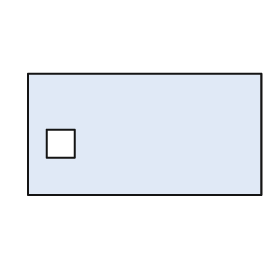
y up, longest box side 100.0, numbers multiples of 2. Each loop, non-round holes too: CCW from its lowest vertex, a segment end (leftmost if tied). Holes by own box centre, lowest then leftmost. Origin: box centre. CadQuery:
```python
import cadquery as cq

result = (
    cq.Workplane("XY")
    .moveTo(-50.0, -26.0)
    .lineTo(50.0, -26.0)
    .lineTo(50.0, 26.0)
    .lineTo(-50.0, 26.0)
    .close()
    .moveTo(-42.0, -10.0)
    .lineTo(-30.0, -10.0)
    .lineTo(-30.0, 2.0)
    .lineTo(-42.0, 2.0)
    .close()
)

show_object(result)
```